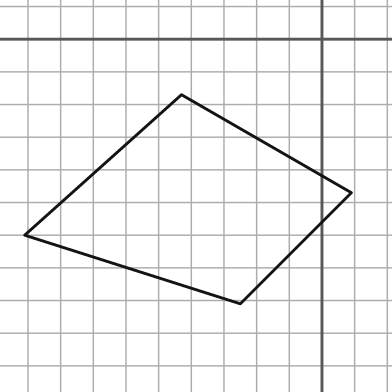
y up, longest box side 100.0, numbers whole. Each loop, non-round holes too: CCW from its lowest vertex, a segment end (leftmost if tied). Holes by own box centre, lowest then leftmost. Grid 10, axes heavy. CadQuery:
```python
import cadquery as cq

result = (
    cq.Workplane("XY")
    .moveTo(-25.0, -81.0)
    .lineTo(9.0, -47.0)
    .lineTo(-43.0, -17.0)
    .lineTo(-91.0, -60.0)
    .close()
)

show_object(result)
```